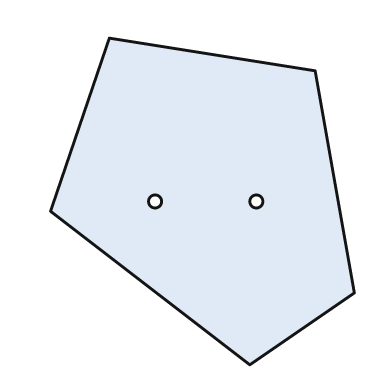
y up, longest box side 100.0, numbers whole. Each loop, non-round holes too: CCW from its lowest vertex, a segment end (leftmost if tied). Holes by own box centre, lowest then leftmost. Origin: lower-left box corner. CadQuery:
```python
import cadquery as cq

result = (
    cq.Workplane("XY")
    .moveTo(61.0, 0.0)
    .lineTo(93.0, 22.0)
    .lineTo(81.0, 90.0)
    .lineTo(18.0, 100.0)
    .lineTo(0.0, 47.0)
    .close()
    .moveTo(32.0, 50.0)
    .circle(2.0)
    .moveTo(63.0, 50.0)
    .circle(2.0)
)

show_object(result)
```